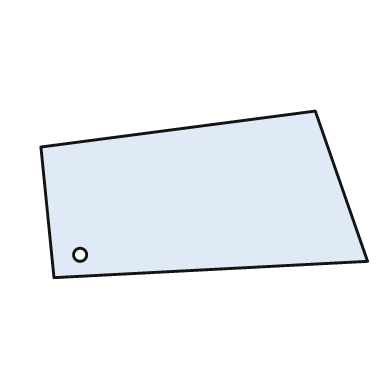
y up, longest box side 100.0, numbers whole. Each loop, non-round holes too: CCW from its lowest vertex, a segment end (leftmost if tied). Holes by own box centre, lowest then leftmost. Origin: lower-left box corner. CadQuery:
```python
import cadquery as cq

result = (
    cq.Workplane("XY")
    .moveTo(4.0, 0.0)
    .lineTo(100.0, 5.0)
    .lineTo(84.0, 51.0)
    .lineTo(0.0, 40.0)
    .close()
    .moveTo(12.0, 7.0)
    .circle(2.0)
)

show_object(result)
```